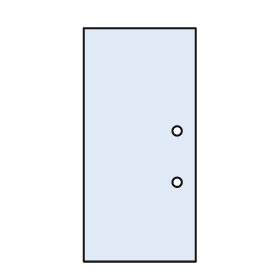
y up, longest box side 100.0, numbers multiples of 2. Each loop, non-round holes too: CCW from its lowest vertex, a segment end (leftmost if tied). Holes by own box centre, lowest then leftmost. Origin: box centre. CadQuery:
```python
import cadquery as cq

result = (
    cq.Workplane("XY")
    .moveTo(-24.0, -50.0)
    .lineTo(24.0, -50.0)
    .lineTo(24.0, 50.0)
    .lineTo(-24.0, 50.0)
    .close()
    .moveTo(16.0, -16.0)
    .circle(2.0)
    .moveTo(16.0, 6.0)
    .circle(2.0)
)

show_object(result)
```